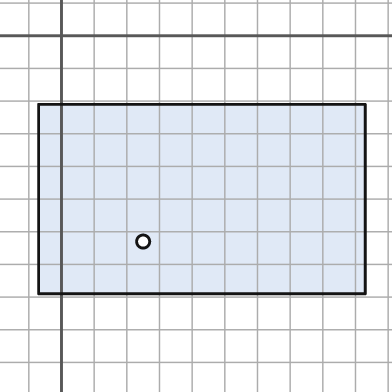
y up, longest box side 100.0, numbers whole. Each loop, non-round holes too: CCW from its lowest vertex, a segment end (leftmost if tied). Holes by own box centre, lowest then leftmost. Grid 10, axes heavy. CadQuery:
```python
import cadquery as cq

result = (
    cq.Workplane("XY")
    .moveTo(-7.0, -79.0)
    .lineTo(93.0, -79.0)
    .lineTo(93.0, -21.0)
    .lineTo(-7.0, -21.0)
    .close()
    .moveTo(25.0, -63.0)
    .circle(2.0)
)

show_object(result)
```